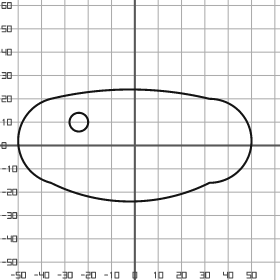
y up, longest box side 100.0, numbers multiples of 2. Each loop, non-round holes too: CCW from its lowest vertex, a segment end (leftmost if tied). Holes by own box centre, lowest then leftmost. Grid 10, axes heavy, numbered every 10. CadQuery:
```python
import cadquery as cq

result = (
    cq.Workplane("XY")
    .moveTo(-36.0, -16.0)
    .threePointArc((-2.0, -24.0), (32.0, -16.0))
    .threePointArc((50.0, 2.0), (32.0, 20.0))
    .threePointArc((-2.0, 24.0), (-36.0, 20.0))
    .threePointArc((-50.0, 2.0), (-36.0, -16.0))
    .close()
    .moveTo(-24.0, 10.0)
    .circle(4.0)
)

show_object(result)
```